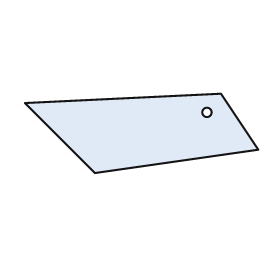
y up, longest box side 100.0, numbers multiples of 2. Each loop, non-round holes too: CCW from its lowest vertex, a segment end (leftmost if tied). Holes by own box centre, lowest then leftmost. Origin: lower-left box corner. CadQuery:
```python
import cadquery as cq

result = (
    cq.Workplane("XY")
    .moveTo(30.0, 0.0)
    .lineTo(100.0, 10.0)
    .lineTo(84.0, 34.0)
    .lineTo(0.0, 30.0)
    .close()
    .moveTo(78.0, 26.0)
    .circle(2.0)
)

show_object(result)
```